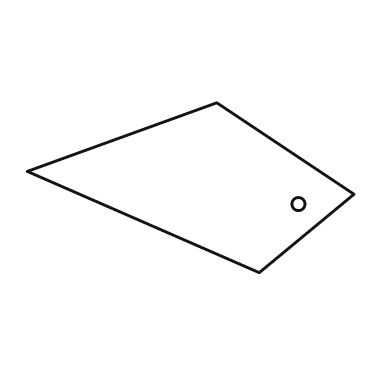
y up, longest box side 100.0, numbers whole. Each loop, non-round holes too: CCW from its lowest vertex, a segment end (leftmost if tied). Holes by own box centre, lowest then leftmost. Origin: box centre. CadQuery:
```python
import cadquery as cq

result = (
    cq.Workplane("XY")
    .moveTo(21.0, -26.0)
    .lineTo(50.0, -2.0)
    .lineTo(8.0, 26.0)
    .lineTo(-50.0, 5.0)
    .close()
    .moveTo(33.0, -5.0)
    .circle(2.0)
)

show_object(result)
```